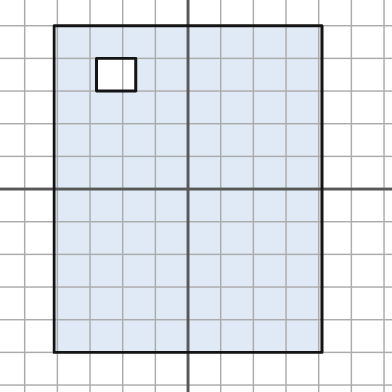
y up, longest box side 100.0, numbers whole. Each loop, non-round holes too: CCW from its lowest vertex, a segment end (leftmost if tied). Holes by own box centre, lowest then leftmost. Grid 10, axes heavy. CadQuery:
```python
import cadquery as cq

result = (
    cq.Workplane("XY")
    .moveTo(-41.0, -50.0)
    .lineTo(41.0, -50.0)
    .lineTo(41.0, 50.0)
    .lineTo(-41.0, 50.0)
    .close()
    .moveTo(-28.0, 30.0)
    .lineTo(-16.0, 30.0)
    .lineTo(-16.0, 40.0)
    .lineTo(-28.0, 40.0)
    .close()
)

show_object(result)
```